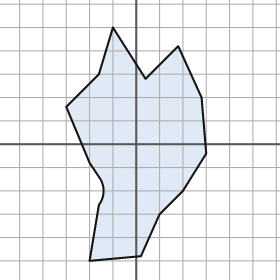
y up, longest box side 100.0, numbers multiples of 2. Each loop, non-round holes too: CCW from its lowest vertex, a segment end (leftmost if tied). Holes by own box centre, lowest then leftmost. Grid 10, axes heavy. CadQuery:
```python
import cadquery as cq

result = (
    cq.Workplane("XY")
    .moveTo(-20.0, -50.0)
    .lineTo(2.0, -48.0)
    .lineTo(10.0, -30.0)
    .lineTo(20.0, -20.0)
    .lineTo(30.0, -4.0)
    .lineTo(28.0, 20.0)
    .lineTo(18.0, 42.0)
    .lineTo(4.0, 28.0)
    .lineTo(-10.0, 50.0)
    .lineTo(-16.0, 30.0)
    .lineTo(-30.0, 16.0)
    .lineTo(-20.0, -8.0)
    .lineTo(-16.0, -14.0)
    .threePointArc((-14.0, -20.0), (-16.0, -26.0))
    .close()
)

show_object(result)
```